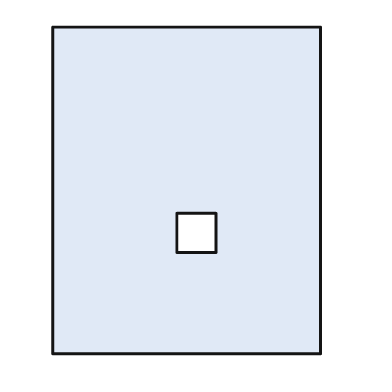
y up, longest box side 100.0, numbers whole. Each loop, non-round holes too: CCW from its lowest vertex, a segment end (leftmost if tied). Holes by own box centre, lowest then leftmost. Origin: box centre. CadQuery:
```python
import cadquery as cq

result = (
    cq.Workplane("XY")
    .moveTo(-41.0, -50.0)
    .lineTo(41.0, -50.0)
    .lineTo(41.0, 50.0)
    .lineTo(-41.0, 50.0)
    .close()
    .moveTo(-3.0, -19.0)
    .lineTo(9.0, -19.0)
    .lineTo(9.0, -7.0)
    .lineTo(-3.0, -7.0)
    .close()
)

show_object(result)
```